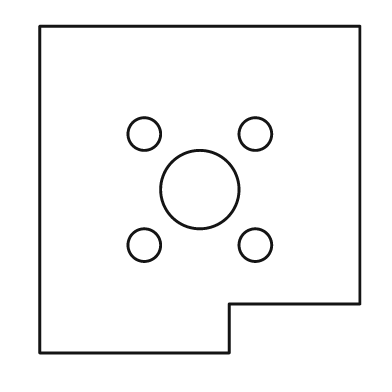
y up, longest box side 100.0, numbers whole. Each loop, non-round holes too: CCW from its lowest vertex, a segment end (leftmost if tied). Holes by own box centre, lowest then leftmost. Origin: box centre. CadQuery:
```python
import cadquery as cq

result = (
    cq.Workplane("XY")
    .moveTo(-49.0, -50.0)
    .lineTo(9.0, -50.0)
    .lineTo(9.0, -35.0)
    .lineTo(49.0, -35.0)
    .lineTo(49.0, 50.0)
    .lineTo(-49.0, 50.0)
    .close()
    .moveTo(-17.0, -17.0)
    .circle(5.0)
    .moveTo(17.0, -17.0)
    .circle(5.0)
    .moveTo(0.0, 0.0)
    .circle(12.0)
    .moveTo(-17.0, 17.0)
    .circle(5.0)
    .moveTo(17.0, 17.0)
    .circle(5.0)
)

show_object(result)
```